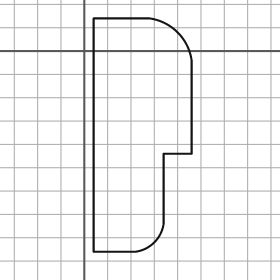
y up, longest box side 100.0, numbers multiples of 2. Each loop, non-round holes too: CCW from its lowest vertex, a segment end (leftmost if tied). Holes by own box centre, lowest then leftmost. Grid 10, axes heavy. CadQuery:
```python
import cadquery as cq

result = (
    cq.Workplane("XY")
    .moveTo(4.0, -86.0)
    .lineTo(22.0, -86.0)
    .threePointArc((30.0, -82.0), (34.0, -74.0))
    .lineTo(34.0, -44.0)
    .lineTo(46.0, -44.0)
    .lineTo(46.0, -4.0)
    .threePointArc((40.0, 8.0), (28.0, 14.0))
    .lineTo(4.0, 14.0)
    .close()
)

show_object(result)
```